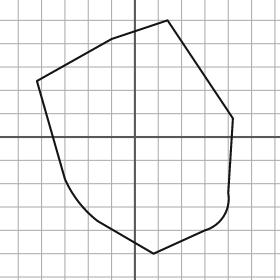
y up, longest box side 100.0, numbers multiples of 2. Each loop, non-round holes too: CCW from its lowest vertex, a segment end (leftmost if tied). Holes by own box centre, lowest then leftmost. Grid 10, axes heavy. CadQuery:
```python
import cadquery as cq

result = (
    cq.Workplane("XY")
    .moveTo(8.0, -50.0)
    .lineTo(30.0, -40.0)
    .threePointArc((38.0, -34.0), (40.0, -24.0))
    .lineTo(42.0, 8.0)
    .lineTo(14.0, 50.0)
    .lineTo(-10.0, 42.0)
    .lineTo(-42.0, 24.0)
    .lineTo(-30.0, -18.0)
    .threePointArc((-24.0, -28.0), (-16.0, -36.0))
    .close()
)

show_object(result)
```